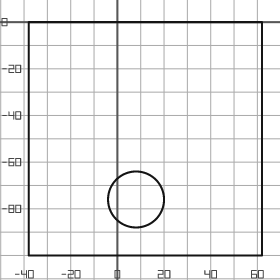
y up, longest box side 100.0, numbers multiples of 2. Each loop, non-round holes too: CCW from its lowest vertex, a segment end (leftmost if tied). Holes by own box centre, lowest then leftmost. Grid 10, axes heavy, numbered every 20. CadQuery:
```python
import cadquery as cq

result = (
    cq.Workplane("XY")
    .moveTo(-38.0, -100.0)
    .lineTo(62.0, -100.0)
    .lineTo(62.0, 0.0)
    .lineTo(-38.0, 0.0)
    .close()
    .moveTo(8.0, -76.0)
    .circle(12.0)
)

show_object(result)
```